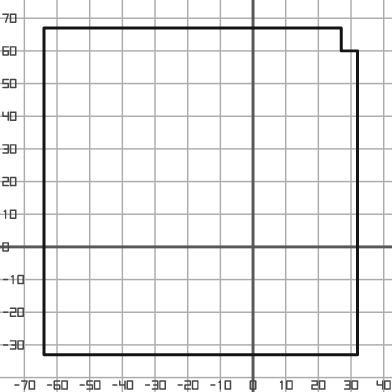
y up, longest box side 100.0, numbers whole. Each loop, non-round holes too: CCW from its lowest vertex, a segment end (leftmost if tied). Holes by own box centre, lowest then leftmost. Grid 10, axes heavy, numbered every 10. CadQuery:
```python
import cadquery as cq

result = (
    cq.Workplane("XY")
    .moveTo(-64.0, -33.0)
    .lineTo(32.0, -33.0)
    .lineTo(32.0, 60.0)
    .lineTo(27.0, 60.0)
    .lineTo(27.0, 67.0)
    .lineTo(-64.0, 67.0)
    .close()
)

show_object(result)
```